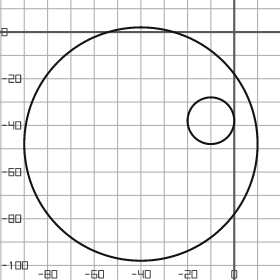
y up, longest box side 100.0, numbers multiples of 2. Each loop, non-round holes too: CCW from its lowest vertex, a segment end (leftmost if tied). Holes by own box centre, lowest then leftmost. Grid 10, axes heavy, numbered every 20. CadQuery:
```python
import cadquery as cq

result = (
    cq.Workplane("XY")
    .moveTo(-40.0, -48.0)
    .circle(50.0)
    .moveTo(-10.0, -38.0)
    .circle(10.0)
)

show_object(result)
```